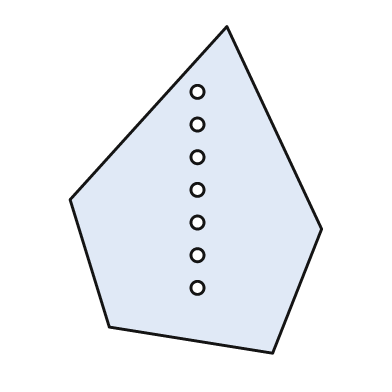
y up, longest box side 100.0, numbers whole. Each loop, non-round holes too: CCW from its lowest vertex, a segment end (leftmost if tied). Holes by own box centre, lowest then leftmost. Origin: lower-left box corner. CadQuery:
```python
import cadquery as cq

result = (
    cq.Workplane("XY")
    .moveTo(62.0, 0.0)
    .lineTo(77.0, 38.0)
    .lineTo(48.0, 100.0)
    .lineTo(0.0, 47.0)
    .lineTo(12.0, 8.0)
    .close()
    .moveTo(39.0, 20.0)
    .circle(2.0)
    .moveTo(39.0, 30.0)
    .circle(2.0)
    .moveTo(39.0, 40.0)
    .circle(2.0)
    .moveTo(39.0, 50.0)
    .circle(2.0)
    .moveTo(39.0, 60.0)
    .circle(2.0)
    .moveTo(39.0, 70.0)
    .circle(2.0)
    .moveTo(39.0, 80.0)
    .circle(2.0)
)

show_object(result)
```